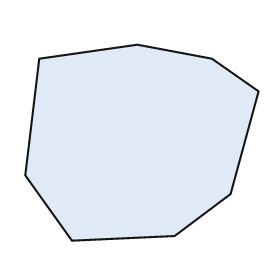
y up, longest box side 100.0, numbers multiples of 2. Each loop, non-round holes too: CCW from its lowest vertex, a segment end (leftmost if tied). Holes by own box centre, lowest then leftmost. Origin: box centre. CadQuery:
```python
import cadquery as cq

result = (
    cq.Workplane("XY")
    .moveTo(-30.0, -42.0)
    .lineTo(14.0, -40.0)
    .lineTo(38.0, -22.0)
    .lineTo(50.0, 22.0)
    .lineTo(30.0, 36.0)
    .lineTo(-2.0, 42.0)
    .lineTo(-44.0, 36.0)
    .lineTo(-50.0, -14.0)
    .close()
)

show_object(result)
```